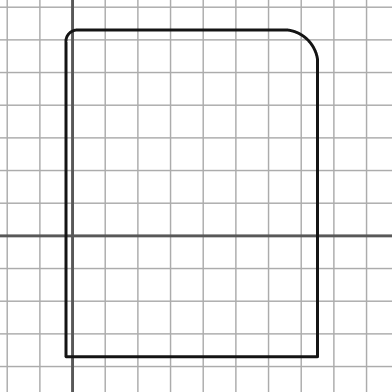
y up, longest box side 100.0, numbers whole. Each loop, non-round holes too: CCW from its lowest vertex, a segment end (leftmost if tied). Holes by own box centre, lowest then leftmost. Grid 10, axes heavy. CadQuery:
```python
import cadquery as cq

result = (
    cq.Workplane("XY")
    .moveTo(-2.0, -37.0)
    .lineTo(75.0, -37.0)
    .lineTo(75.0, 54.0)
    .threePointArc((72.0, 60.0), (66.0, 63.0))
    .lineTo(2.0, 63.0)
    .threePointArc((-1.0, 62.0), (-2.0, 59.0))
    .close()
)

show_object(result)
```